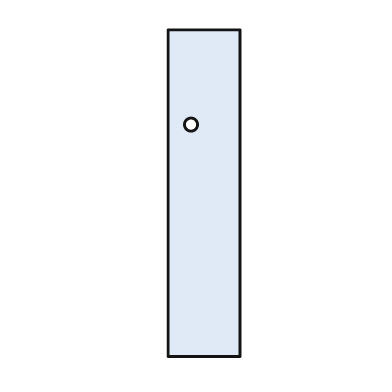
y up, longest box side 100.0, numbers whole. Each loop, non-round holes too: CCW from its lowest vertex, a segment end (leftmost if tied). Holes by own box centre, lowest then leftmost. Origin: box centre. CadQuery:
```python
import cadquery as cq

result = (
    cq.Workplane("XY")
    .moveTo(-11.0, -50.0)
    .lineTo(11.0, -50.0)
    .lineTo(11.0, 50.0)
    .lineTo(-11.0, 50.0)
    .close()
    .moveTo(-4.0, 21.0)
    .circle(2.0)
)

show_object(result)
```